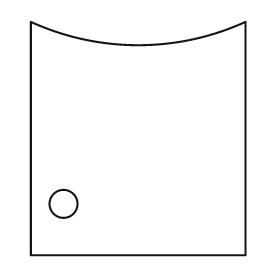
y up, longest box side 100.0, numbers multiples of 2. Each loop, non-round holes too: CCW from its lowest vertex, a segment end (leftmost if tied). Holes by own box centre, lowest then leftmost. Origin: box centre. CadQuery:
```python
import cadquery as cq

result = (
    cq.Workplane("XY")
    .moveTo(-46.0, -50.0)
    .lineTo(46.0, -50.0)
    .lineTo(46.0, 50.0)
    .threePointArc((0.0, 40.0), (-46.0, 50.0))
    .close()
    .moveTo(-32.0, -28.0)
    .circle(6.0)
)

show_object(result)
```